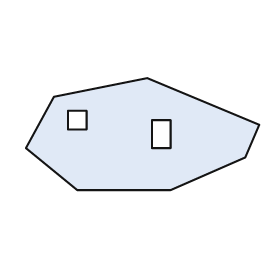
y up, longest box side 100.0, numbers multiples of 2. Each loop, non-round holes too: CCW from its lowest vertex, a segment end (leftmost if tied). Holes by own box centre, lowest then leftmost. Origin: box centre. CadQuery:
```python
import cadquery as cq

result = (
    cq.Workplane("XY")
    .moveTo(-28.0, -24.0)
    .lineTo(12.0, -24.0)
    .lineTo(44.0, -10.0)
    .lineTo(50.0, 4.0)
    .lineTo(2.0, 24.0)
    .lineTo(-38.0, 16.0)
    .lineTo(-50.0, -6.0)
    .close()
    .moveTo(4.0, -6.0)
    .lineTo(12.0, -6.0)
    .lineTo(12.0, 6.0)
    .lineTo(4.0, 6.0)
    .close()
    .moveTo(-32.0, 2.0)
    .lineTo(-24.0, 2.0)
    .lineTo(-24.0, 10.0)
    .lineTo(-32.0, 10.0)
    .close()
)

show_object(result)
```